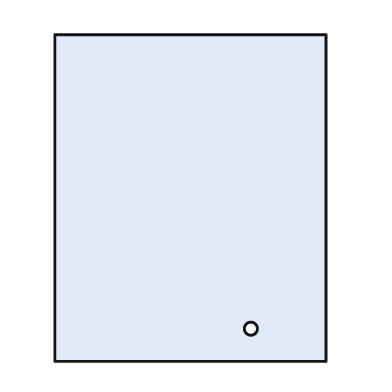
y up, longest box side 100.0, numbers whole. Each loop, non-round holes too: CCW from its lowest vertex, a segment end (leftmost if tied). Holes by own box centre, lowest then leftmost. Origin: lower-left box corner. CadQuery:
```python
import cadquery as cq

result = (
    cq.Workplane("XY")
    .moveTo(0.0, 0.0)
    .lineTo(83.0, 0.0)
    .lineTo(83.0, 100.0)
    .lineTo(0.0, 100.0)
    .close()
    .moveTo(60.0, 10.0)
    .circle(2.0)
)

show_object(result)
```